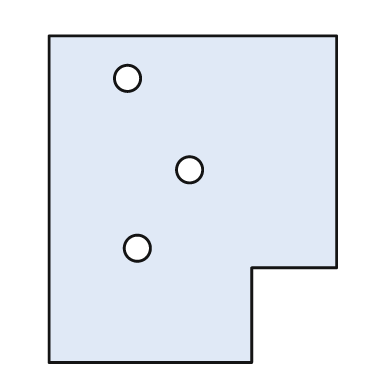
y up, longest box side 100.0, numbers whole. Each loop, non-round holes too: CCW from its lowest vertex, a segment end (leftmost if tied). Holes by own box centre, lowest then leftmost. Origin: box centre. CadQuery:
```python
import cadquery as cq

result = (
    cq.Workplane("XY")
    .moveTo(-44.0, -50.0)
    .lineTo(18.0, -50.0)
    .lineTo(18.0, -21.0)
    .lineTo(44.0, -21.0)
    .lineTo(44.0, 50.0)
    .lineTo(-44.0, 50.0)
    .close()
    .moveTo(-17.0, -15.0)
    .circle(4.0)
    .moveTo(-1.0, 9.0)
    .circle(4.0)
    .moveTo(-20.0, 37.0)
    .circle(4.0)
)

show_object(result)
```